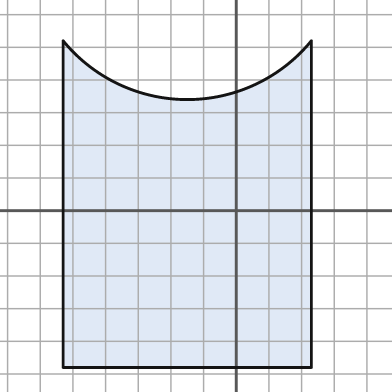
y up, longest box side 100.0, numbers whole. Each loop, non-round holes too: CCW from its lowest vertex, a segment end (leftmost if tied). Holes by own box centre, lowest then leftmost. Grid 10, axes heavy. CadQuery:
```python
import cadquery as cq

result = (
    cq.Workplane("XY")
    .moveTo(-53.0, -48.0)
    .lineTo(23.0, -48.0)
    .lineTo(23.0, 52.0)
    .threePointArc((-15.0, 34.0), (-53.0, 52.0))
    .close()
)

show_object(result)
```